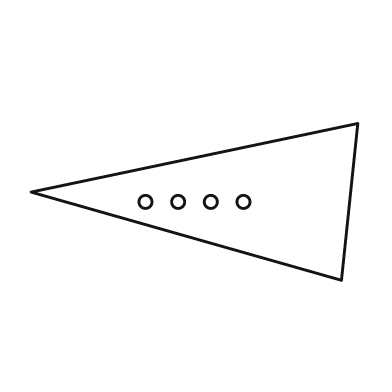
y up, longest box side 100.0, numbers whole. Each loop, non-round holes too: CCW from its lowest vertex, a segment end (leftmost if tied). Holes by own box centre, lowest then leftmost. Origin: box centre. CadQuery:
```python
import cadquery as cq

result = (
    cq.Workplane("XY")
    .moveTo(45.0, -24.0)
    .lineTo(50.0, 24.0)
    .lineTo(-50.0, 3.0)
    .close()
    .moveTo(-15.0, 0.0)
    .circle(2.0)
    .moveTo(-5.0, 0.0)
    .circle(2.0)
    .moveTo(5.0, 0.0)
    .circle(2.0)
    .moveTo(15.0, 0.0)
    .circle(2.0)
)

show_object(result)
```